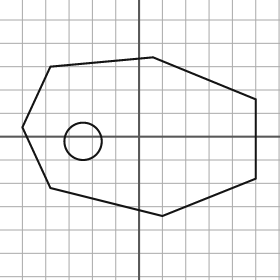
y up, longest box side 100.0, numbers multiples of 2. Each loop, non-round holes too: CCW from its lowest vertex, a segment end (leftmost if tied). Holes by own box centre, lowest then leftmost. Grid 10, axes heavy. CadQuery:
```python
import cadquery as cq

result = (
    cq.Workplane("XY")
    .moveTo(10.0, -34.0)
    .lineTo(50.0, -18.0)
    .lineTo(50.0, 16.0)
    .lineTo(6.0, 34.0)
    .lineTo(-38.0, 30.0)
    .lineTo(-50.0, 4.0)
    .lineTo(-38.0, -22.0)
    .close()
    .moveTo(-24.0, -2.0)
    .circle(8.0)
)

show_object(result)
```